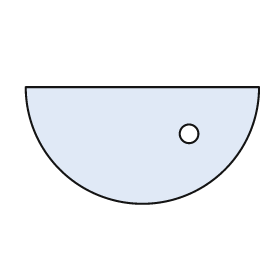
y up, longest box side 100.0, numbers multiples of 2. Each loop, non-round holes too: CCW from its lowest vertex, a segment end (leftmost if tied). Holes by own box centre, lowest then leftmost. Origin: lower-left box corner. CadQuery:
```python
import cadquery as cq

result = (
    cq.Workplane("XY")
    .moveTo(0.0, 50.0)
    .threePointArc((50.0, 0.0), (100.0, 50.0))
    .close()
    .moveTo(70.0, 30.0)
    .circle(4.0)
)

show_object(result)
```